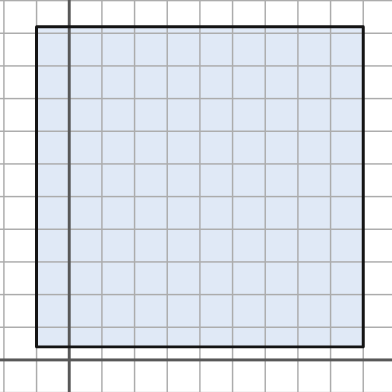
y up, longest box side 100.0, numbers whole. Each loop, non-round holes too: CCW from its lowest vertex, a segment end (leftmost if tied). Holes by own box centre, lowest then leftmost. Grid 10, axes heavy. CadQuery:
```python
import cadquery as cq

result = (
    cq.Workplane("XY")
    .moveTo(-10.0, 4.0)
    .lineTo(90.0, 4.0)
    .lineTo(90.0, 102.0)
    .lineTo(-10.0, 102.0)
    .close()
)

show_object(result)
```